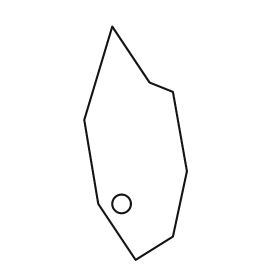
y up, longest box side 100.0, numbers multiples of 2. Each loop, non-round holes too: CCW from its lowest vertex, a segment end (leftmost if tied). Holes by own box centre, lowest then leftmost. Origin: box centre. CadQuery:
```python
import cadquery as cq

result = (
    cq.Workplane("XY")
    .moveTo(0.0, -50.0)
    .lineTo(16.0, -40.0)
    .lineTo(22.0, -12.0)
    .lineTo(16.0, 22.0)
    .lineTo(6.0, 26.0)
    .lineTo(-10.0, 50.0)
    .lineTo(-22.0, 10.0)
    .lineTo(-16.0, -26.0)
    .close()
    .moveTo(-6.0, -26.0)
    .circle(4.0)
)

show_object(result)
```